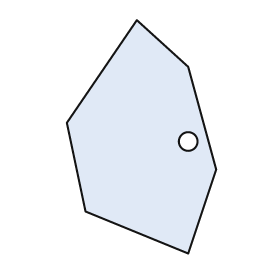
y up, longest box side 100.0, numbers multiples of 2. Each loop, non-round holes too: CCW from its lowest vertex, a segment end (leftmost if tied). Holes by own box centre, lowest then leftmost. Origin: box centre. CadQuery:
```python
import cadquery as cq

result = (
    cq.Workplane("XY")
    .moveTo(20.0, -50.0)
    .lineTo(32.0, -14.0)
    .lineTo(20.0, 30.0)
    .lineTo(-2.0, 50.0)
    .lineTo(-32.0, 6.0)
    .lineTo(-24.0, -32.0)
    .close()
    .moveTo(20.0, -2.0)
    .circle(4.0)
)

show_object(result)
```